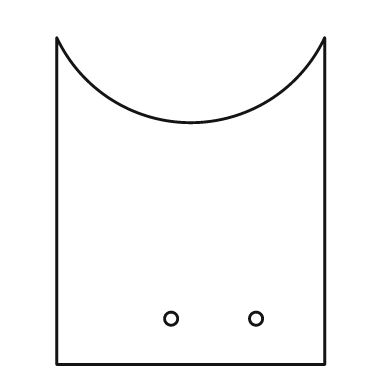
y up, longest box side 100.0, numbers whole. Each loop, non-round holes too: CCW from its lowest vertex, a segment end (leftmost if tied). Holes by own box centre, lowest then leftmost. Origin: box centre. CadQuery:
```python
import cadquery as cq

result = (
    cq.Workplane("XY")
    .moveTo(-41.0, -50.0)
    .lineTo(41.0, -50.0)
    .lineTo(41.0, 50.0)
    .threePointArc((0.0, 24.0), (-41.0, 50.0))
    .close()
    .moveTo(-6.0, -36.0)
    .circle(2.0)
    .moveTo(20.0, -36.0)
    .circle(2.0)
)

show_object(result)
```